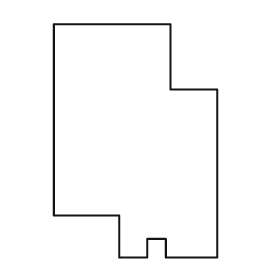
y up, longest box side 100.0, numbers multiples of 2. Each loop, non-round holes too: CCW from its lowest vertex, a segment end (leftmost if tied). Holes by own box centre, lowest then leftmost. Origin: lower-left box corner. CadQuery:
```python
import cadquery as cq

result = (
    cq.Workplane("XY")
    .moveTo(28.0, 0.0)
    .lineTo(40.0, 0.0)
    .lineTo(40.0, 8.0)
    .lineTo(48.0, 8.0)
    .lineTo(48.0, 0.0)
    .lineTo(70.0, 0.0)
    .lineTo(70.0, 72.0)
    .lineTo(50.0, 72.0)
    .lineTo(50.0, 100.0)
    .lineTo(0.0, 100.0)
    .lineTo(0.0, 18.0)
    .lineTo(28.0, 18.0)
    .close()
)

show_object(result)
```